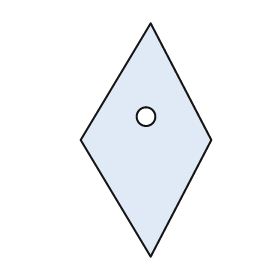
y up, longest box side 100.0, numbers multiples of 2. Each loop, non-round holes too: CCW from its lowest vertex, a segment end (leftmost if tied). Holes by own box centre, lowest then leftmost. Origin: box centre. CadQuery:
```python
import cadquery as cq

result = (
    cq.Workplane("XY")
    .moveTo(2.0, -50.0)
    .lineTo(28.0, 0.0)
    .lineTo(2.0, 50.0)
    .lineTo(-28.0, 0.0)
    .close()
    .moveTo(0.0, 10.0)
    .circle(4.0)
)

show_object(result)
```